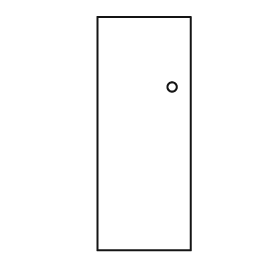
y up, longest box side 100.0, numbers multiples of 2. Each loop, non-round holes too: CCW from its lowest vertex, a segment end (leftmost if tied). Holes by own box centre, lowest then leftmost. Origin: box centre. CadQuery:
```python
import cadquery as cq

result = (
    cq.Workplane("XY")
    .moveTo(-20.0, -50.0)
    .lineTo(20.0, -50.0)
    .lineTo(20.0, 50.0)
    .lineTo(-20.0, 50.0)
    .close()
    .moveTo(12.0, 20.0)
    .circle(2.0)
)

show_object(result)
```